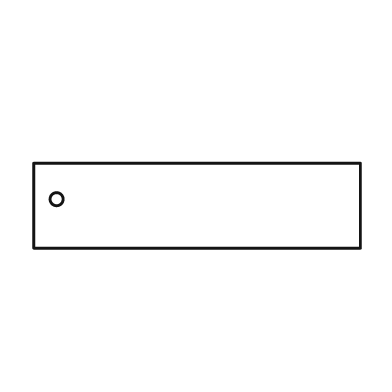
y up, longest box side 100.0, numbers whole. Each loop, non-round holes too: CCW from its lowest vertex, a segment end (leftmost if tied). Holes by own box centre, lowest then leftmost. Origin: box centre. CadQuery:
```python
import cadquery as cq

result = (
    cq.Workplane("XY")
    .moveTo(-50.0, -13.0)
    .lineTo(50.0, -13.0)
    .lineTo(50.0, 13.0)
    .lineTo(-50.0, 13.0)
    .close()
    .moveTo(-43.0, 2.0)
    .circle(2.0)
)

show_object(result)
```